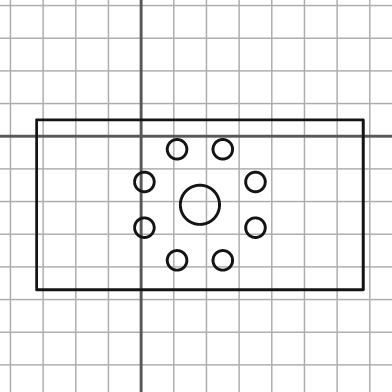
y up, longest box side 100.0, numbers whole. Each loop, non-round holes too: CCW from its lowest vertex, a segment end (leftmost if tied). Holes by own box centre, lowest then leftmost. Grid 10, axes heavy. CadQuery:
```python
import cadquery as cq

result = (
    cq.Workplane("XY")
    .moveTo(-32.0, -47.0)
    .lineTo(68.0, -47.0)
    .lineTo(68.0, 5.0)
    .lineTo(-32.0, 5.0)
    .close()
    .moveTo(11.0, -38.0)
    .circle(3.0)
    .moveTo(25.0, -38.0)
    .circle(3.0)
    .moveTo(1.0, -28.0)
    .circle(3.0)
    .moveTo(35.0, -28.0)
    .circle(3.0)
    .moveTo(18.0, -21.0)
    .circle(6.0)
    .moveTo(1.0, -14.0)
    .circle(3.0)
    .moveTo(35.0, -14.0)
    .circle(3.0)
    .moveTo(11.0, -4.0)
    .circle(3.0)
    .moveTo(25.0, -4.0)
    .circle(3.0)
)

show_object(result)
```